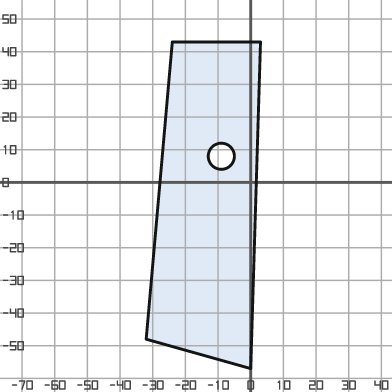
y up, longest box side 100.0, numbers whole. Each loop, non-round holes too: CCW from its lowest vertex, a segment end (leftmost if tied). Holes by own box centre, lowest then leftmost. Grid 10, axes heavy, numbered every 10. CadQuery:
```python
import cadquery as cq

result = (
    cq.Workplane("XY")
    .moveTo(0.0, -57.0)
    .lineTo(3.0, 43.0)
    .lineTo(-24.0, 43.0)
    .lineTo(-32.0, -48.0)
    .close()
    .moveTo(-9.0, 8.0)
    .circle(4.0)
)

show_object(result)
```